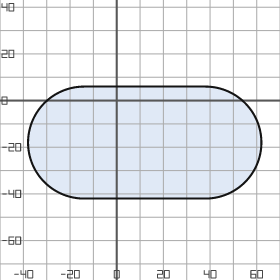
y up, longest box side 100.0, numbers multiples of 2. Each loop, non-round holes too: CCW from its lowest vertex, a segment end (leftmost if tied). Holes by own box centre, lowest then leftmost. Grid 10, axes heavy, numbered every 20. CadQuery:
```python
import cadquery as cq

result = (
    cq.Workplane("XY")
    .moveTo(-14.0, -42.0)
    .lineTo(38.0, -42.0)
    .threePointArc((62.0, -18.0), (38.0, 6.0))
    .lineTo(-14.0, 6.0)
    .threePointArc((-38.0, -18.0), (-14.0, -42.0))
    .close()
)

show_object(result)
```